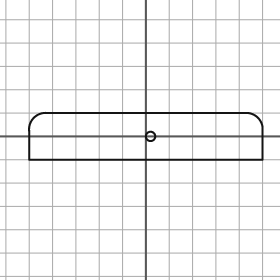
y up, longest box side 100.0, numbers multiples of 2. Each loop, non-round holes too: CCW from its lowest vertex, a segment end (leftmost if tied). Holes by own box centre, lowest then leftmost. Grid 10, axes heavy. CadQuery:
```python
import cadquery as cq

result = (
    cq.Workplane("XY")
    .moveTo(-50.0, -10.0)
    .lineTo(50.0, -10.0)
    .lineTo(50.0, 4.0)
    .threePointArc((48.0, 8.0), (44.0, 10.0))
    .lineTo(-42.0, 10.0)
    .threePointArc((-48.0, 8.0), (-50.0, 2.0))
    .close()
    .moveTo(2.0, 0.0)
    .circle(2.0)
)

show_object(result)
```